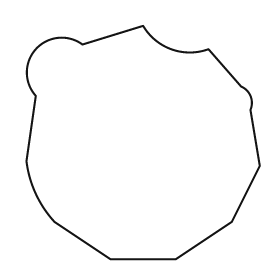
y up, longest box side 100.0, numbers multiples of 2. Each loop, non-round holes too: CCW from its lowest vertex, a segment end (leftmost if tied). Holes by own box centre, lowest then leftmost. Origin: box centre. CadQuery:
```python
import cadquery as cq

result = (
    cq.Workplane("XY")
    .moveTo(-14.0, -50.0)
    .lineTo(14.0, -50.0)
    .lineTo(38.0, -34.0)
    .lineTo(50.0, -10.0)
    .lineTo(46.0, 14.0)
    .threePointArc((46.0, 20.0), (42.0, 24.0))
    .lineTo(28.0, 40.0)
    .threePointArc((12.0, 40.0), (0.0, 50.0))
    .lineTo(-26.0, 42.0)
    .threePointArc((-46.0, 40.0), (-46.0, 20.0))
    .lineTo(-50.0, -8.0)
    .threePointArc((-46.0, -22.0), (-38.0, -34.0))
    .close()
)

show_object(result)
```